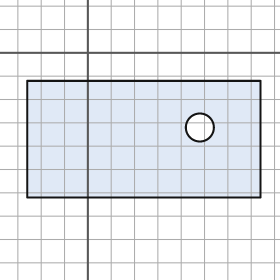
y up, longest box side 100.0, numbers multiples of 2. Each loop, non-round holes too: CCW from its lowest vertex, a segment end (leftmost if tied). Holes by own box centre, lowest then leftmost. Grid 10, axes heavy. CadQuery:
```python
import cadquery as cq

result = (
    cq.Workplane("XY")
    .moveTo(-26.0, -62.0)
    .lineTo(74.0, -62.0)
    .lineTo(74.0, -12.0)
    .lineTo(-26.0, -12.0)
    .close()
    .moveTo(48.0, -32.0)
    .circle(6.0)
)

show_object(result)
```